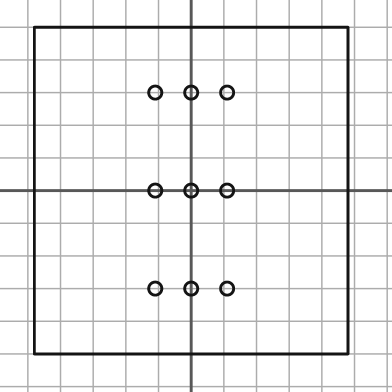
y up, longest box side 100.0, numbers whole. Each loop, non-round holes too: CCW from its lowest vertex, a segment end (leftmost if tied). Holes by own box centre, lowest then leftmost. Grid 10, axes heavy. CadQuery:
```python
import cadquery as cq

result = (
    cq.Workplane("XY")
    .moveTo(-48.0, -50.0)
    .lineTo(48.0, -50.0)
    .lineTo(48.0, 50.0)
    .lineTo(-48.0, 50.0)
    .close()
    .moveTo(-11.0, -30.0)
    .circle(2.0)
    .moveTo(0.0, -30.0)
    .circle(2.0)
    .moveTo(11.0, -30.0)
    .circle(2.0)
    .moveTo(-11.0, 0.0)
    .circle(2.0)
    .moveTo(0.0, 0.0)
    .circle(2.0)
    .moveTo(11.0, 0.0)
    .circle(2.0)
    .moveTo(-11.0, 30.0)
    .circle(2.0)
    .moveTo(0.0, 30.0)
    .circle(2.0)
    .moveTo(11.0, 30.0)
    .circle(2.0)
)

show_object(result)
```